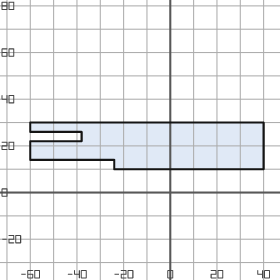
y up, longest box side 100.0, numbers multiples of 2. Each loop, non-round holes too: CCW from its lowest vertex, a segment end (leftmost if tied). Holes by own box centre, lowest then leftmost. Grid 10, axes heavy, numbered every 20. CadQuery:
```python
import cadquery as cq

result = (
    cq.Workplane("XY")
    .moveTo(-24.0, 10.0)
    .lineTo(40.0, 10.0)
    .lineTo(40.0, 30.0)
    .lineTo(-60.0, 30.0)
    .lineTo(-60.0, 26.0)
    .lineTo(-38.0, 26.0)
    .lineTo(-38.0, 22.0)
    .lineTo(-60.0, 22.0)
    .lineTo(-60.0, 14.0)
    .lineTo(-24.0, 14.0)
    .close()
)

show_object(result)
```